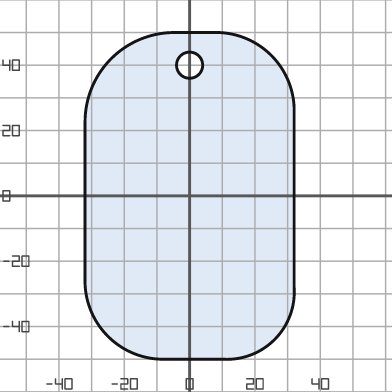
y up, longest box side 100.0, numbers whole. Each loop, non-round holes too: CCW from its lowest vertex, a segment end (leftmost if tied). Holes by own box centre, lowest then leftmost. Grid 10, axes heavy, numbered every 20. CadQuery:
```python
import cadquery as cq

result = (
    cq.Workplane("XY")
    .moveTo(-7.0, -50.0)
    .lineTo(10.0, -50.0)
    .threePointArc((26.0, -44.0), (32.0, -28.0))
    .lineTo(32.0, 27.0)
    .threePointArc((25.0, 43.0), (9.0, 50.0))
    .lineTo(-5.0, 50.0)
    .threePointArc((-24.0, 42.0), (-32.0, 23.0))
    .lineTo(-32.0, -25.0)
    .threePointArc((-25.0, -43.0), (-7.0, -50.0))
    .close()
    .moveTo(0.0, 40.0)
    .circle(4.0)
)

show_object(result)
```